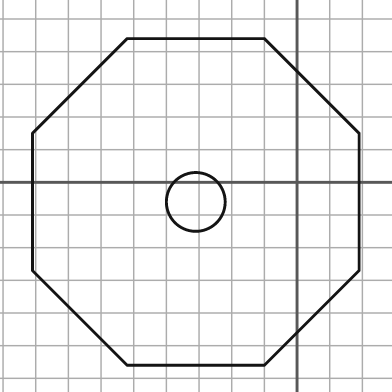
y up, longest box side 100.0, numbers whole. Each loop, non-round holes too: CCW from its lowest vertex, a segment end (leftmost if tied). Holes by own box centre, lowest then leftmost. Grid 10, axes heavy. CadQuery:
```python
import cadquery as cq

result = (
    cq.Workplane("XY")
    .moveTo(-52.0, -56.0)
    .lineTo(-10.0, -56.0)
    .lineTo(19.0, -27.0)
    .lineTo(19.0, 15.0)
    .lineTo(-10.0, 44.0)
    .lineTo(-52.0, 44.0)
    .lineTo(-81.0, 15.0)
    .lineTo(-81.0, -27.0)
    .close()
    .moveTo(-31.0, -6.0)
    .circle(9.0)
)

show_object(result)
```